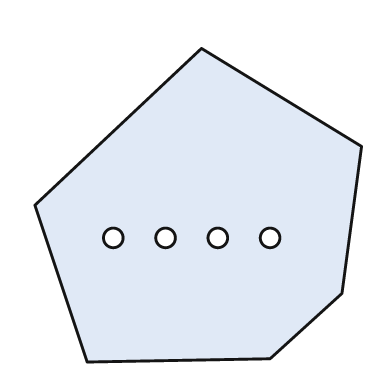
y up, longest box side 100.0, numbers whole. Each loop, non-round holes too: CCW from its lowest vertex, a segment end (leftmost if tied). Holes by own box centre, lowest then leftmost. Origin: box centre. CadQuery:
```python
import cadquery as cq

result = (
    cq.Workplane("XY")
    .moveTo(-34.0, -48.0)
    .lineTo(22.0, -47.0)
    .lineTo(44.0, -27.0)
    .lineTo(50.0, 18.0)
    .lineTo(1.0, 48.0)
    .lineTo(-50.0, 0.0)
    .close()
    .moveTo(-26.0, -10.0)
    .circle(3.0)
    .moveTo(-10.0, -10.0)
    .circle(3.0)
    .moveTo(6.0, -10.0)
    .circle(3.0)
    .moveTo(22.0, -10.0)
    .circle(3.0)
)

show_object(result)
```